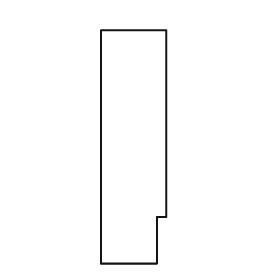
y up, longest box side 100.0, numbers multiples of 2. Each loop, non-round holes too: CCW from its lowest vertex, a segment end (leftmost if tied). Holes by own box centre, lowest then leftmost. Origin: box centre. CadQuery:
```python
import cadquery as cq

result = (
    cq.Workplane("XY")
    .moveTo(-14.0, -50.0)
    .lineTo(10.0, -50.0)
    .lineTo(10.0, -30.0)
    .lineTo(14.0, -30.0)
    .lineTo(14.0, 50.0)
    .lineTo(-14.0, 50.0)
    .close()
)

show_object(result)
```